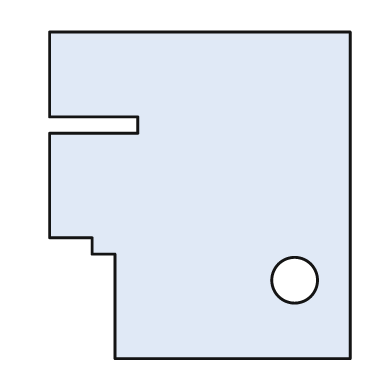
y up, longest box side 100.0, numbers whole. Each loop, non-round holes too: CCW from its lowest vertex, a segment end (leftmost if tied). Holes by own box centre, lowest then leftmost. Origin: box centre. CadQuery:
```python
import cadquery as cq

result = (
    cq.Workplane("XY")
    .moveTo(-26.0, -50.0)
    .lineTo(46.0, -50.0)
    .lineTo(46.0, 50.0)
    .lineTo(-46.0, 50.0)
    .lineTo(-46.0, 24.0)
    .lineTo(-19.0, 24.0)
    .lineTo(-19.0, 19.0)
    .lineTo(-46.0, 19.0)
    .lineTo(-46.0, -13.0)
    .lineTo(-33.0, -13.0)
    .lineTo(-33.0, -18.0)
    .lineTo(-26.0, -18.0)
    .close()
    .moveTo(29.0, -26.0)
    .circle(7.0)
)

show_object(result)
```